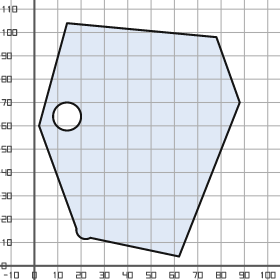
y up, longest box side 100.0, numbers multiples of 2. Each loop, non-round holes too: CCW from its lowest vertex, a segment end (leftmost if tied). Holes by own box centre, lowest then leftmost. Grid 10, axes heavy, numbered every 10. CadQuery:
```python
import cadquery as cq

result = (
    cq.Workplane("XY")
    .moveTo(62.0, 4.0)
    .lineTo(88.0, 70.0)
    .lineTo(78.0, 98.0)
    .lineTo(14.0, 104.0)
    .lineTo(2.0, 60.0)
    .lineTo(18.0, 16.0)
    .threePointArc((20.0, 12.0), (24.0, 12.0))
    .close()
    .moveTo(14.0, 64.0)
    .circle(6.0)
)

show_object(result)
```